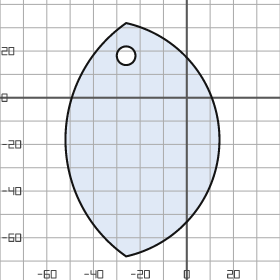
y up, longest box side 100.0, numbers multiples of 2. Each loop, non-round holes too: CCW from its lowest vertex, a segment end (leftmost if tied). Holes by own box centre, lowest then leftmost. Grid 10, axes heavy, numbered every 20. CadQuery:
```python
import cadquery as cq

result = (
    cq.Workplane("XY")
    .moveTo(-26.0, -68.0)
    .threePointArc((14.0, -18.0), (-26.0, 32.0))
    .threePointArc((-52.0, -18.0), (-26.0, -68.0))
    .close()
    .moveTo(-26.0, 18.0)
    .circle(4.0)
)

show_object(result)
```